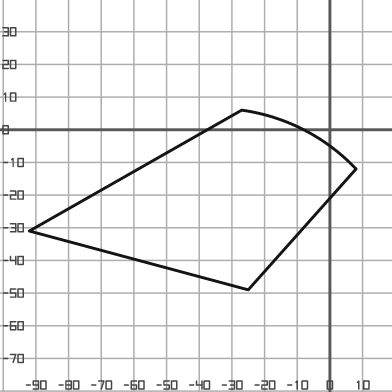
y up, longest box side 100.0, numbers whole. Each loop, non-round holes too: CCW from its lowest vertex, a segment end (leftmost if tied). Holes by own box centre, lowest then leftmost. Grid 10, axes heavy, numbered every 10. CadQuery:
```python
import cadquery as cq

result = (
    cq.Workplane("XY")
    .moveTo(-25.0, -49.0)
    .lineTo(8.0, -12.0)
    .threePointArc((-8.0, 0.0), (-27.0, 6.0))
    .lineTo(-92.0, -31.0)
    .close()
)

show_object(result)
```